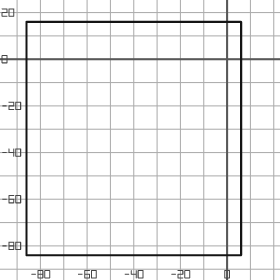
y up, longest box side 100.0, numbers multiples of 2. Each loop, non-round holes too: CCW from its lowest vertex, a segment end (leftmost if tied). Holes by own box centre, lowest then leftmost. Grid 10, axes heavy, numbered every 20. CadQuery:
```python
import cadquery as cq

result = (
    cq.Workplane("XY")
    .moveTo(-86.0, -84.0)
    .lineTo(6.0, -84.0)
    .lineTo(6.0, 16.0)
    .lineTo(-86.0, 16.0)
    .close()
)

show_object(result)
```